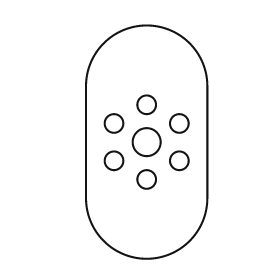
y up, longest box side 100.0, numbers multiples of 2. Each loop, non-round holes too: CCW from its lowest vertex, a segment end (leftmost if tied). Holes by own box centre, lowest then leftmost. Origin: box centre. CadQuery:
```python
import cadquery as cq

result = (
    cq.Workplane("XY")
    .moveTo(-26.0, -24.0)
    .threePointArc((0.0, -50.0), (26.0, -24.0))
    .lineTo(26.0, 24.0)
    .threePointArc((0.0, 50.0), (-26.0, 24.0))
    .close()
    .moveTo(0.0, -16.0)
    .circle(4.0)
    .moveTo(-14.0, -8.0)
    .circle(4.0)
    .moveTo(14.0, -8.0)
    .circle(4.0)
    .moveTo(0.0, 0.0)
    .circle(6.0)
    .moveTo(-14.0, 8.0)
    .circle(4.0)
    .moveTo(14.0, 8.0)
    .circle(4.0)
    .moveTo(0.0, 16.0)
    .circle(4.0)
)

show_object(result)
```